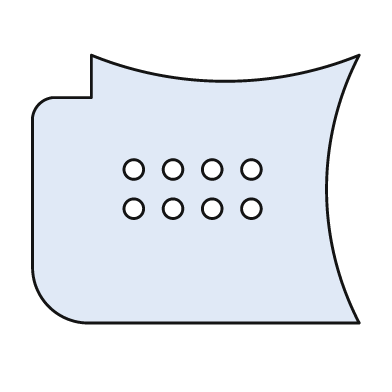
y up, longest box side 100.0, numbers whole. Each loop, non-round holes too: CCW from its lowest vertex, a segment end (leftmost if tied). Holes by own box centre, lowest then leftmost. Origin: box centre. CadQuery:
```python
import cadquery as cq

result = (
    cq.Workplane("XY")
    .moveTo(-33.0, -41.0)
    .lineTo(50.0, -41.0)
    .threePointArc((40.0, 0.0), (50.0, 41.0))
    .threePointArc((9.0, 33.0), (-32.0, 41.0))
    .lineTo(-32.0, 28.0)
    .lineTo(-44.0, 28.0)
    .threePointArc((-48.0, 26.0), (-50.0, 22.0))
    .lineTo(-50.0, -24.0)
    .threePointArc((-45.0, -36.0), (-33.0, -41.0))
    .close()
    .moveTo(-19.0, -6.0)
    .circle(3.0)
    .moveTo(-7.0, -6.0)
    .circle(3.0)
    .moveTo(5.0, -6.0)
    .circle(3.0)
    .moveTo(17.0, -6.0)
    .circle(3.0)
    .moveTo(-19.0, 6.0)
    .circle(3.0)
    .moveTo(-7.0, 6.0)
    .circle(3.0)
    .moveTo(5.0, 6.0)
    .circle(3.0)
    .moveTo(17.0, 6.0)
    .circle(3.0)
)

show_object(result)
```